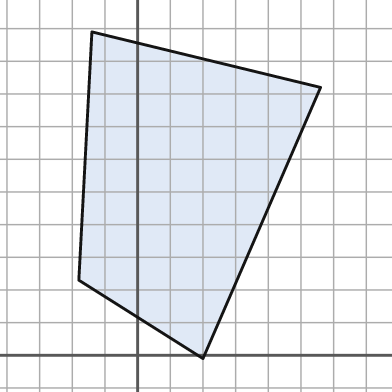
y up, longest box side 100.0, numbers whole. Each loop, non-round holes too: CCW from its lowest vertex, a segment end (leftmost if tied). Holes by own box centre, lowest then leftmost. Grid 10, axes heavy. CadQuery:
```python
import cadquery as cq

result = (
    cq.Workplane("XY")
    .moveTo(20.0, -1.0)
    .lineTo(56.0, 82.0)
    .lineTo(-14.0, 99.0)
    .lineTo(-18.0, 23.0)
    .close()
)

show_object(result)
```